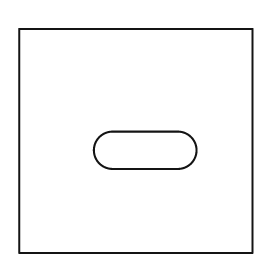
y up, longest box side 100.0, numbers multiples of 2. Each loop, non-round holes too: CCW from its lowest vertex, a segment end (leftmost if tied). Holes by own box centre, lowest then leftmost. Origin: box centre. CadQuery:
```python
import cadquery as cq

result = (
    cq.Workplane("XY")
    .moveTo(-50.0, -48.0)
    .lineTo(50.0, -48.0)
    .lineTo(50.0, 48.0)
    .lineTo(-50.0, 48.0)
    .close()
    .moveTo(-10.0, -12.0)
    .lineTo(18.0, -12.0)
    .threePointArc((26.0, -4.0), (18.0, 4.0))
    .lineTo(-10.0, 4.0)
    .threePointArc((-18.0, -4.0), (-10.0, -12.0))
    .close()
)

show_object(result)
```